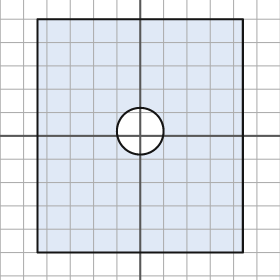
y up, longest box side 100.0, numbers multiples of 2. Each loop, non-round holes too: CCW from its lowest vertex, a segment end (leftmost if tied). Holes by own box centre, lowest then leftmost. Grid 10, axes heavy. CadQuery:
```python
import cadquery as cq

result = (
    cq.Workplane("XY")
    .moveTo(-44.0, -50.0)
    .lineTo(44.0, -50.0)
    .lineTo(44.0, 50.0)
    .lineTo(-44.0, 50.0)
    .close()
    .moveTo(0.0, 2.0)
    .circle(10.0)
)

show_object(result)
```